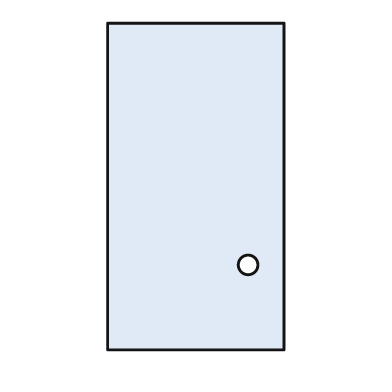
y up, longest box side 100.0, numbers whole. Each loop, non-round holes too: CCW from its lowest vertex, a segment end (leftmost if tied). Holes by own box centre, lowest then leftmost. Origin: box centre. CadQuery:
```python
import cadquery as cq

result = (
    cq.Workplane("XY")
    .moveTo(-27.0, -50.0)
    .lineTo(27.0, -50.0)
    .lineTo(27.0, 50.0)
    .lineTo(-27.0, 50.0)
    .close()
    .moveTo(16.0, -24.0)
    .circle(3.0)
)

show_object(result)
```